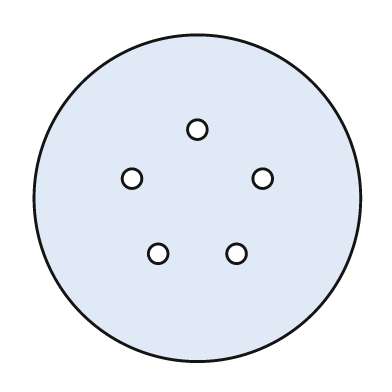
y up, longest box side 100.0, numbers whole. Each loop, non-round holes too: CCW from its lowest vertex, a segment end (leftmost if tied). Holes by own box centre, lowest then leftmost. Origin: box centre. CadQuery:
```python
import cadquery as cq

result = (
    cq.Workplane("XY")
    .moveTo(0.0, 0.0)
    .circle(50.0)
    .moveTo(-12.0, -17.0)
    .circle(3.0)
    .moveTo(12.0, -17.0)
    .circle(3.0)
    .moveTo(-20.0, 6.0)
    .circle(3.0)
    .moveTo(20.0, 6.0)
    .circle(3.0)
    .moveTo(0.0, 21.0)
    .circle(3.0)
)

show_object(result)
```